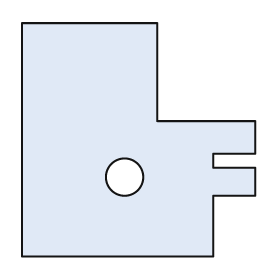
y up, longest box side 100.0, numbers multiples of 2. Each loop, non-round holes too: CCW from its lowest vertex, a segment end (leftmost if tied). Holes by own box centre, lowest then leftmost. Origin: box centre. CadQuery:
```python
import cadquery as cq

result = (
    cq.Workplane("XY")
    .moveTo(-50.0, -50.0)
    .lineTo(32.0, -50.0)
    .lineTo(32.0, -24.0)
    .lineTo(50.0, -24.0)
    .lineTo(50.0, -12.0)
    .lineTo(32.0, -12.0)
    .lineTo(32.0, -6.0)
    .lineTo(50.0, -6.0)
    .lineTo(50.0, 8.0)
    .lineTo(8.0, 8.0)
    .lineTo(8.0, 50.0)
    .lineTo(-50.0, 50.0)
    .close()
    .moveTo(-6.0, -16.0)
    .circle(8.0)
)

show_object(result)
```